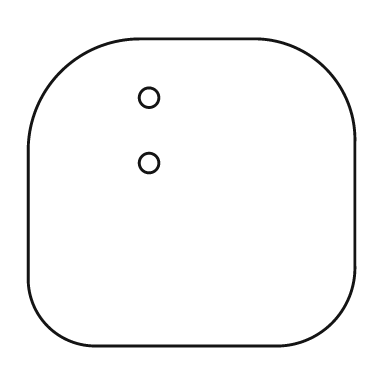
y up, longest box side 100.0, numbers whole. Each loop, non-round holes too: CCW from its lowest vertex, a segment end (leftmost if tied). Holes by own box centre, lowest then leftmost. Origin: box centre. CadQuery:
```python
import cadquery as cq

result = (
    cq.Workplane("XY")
    .moveTo(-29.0, -47.0)
    .lineTo(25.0, -47.0)
    .threePointArc((43.0, -40.0), (50.0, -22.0))
    .lineTo(50.0, 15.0)
    .threePointArc((41.0, 38.0), (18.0, 47.0))
    .lineTo(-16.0, 47.0)
    .threePointArc((-40.0, 37.0), (-50.0, 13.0))
    .lineTo(-50.0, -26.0)
    .threePointArc((-44.0, -41.0), (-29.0, -47.0))
    .close()
    .moveTo(-13.0, 9.0)
    .circle(3.0)
    .moveTo(-13.0, 29.0)
    .circle(3.0)
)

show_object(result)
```